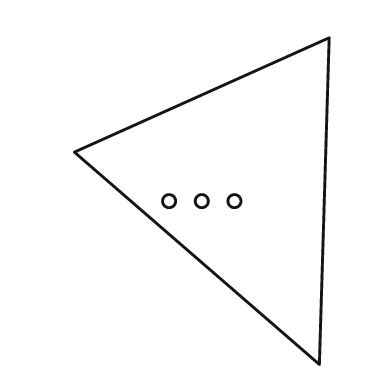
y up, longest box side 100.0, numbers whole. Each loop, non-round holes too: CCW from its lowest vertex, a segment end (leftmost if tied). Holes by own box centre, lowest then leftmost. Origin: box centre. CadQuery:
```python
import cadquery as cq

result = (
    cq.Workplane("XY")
    .moveTo(36.0, -50.0)
    .lineTo(39.0, 50.0)
    .lineTo(-39.0, 15.0)
    .close()
    .moveTo(-10.0, 0.0)
    .circle(2.0)
    .moveTo(0.0, 0.0)
    .circle(2.0)
    .moveTo(10.0, 0.0)
    .circle(2.0)
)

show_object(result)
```